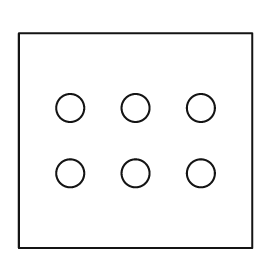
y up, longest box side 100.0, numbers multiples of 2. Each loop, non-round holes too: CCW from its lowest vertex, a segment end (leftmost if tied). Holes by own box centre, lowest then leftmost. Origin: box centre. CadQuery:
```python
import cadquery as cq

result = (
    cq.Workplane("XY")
    .moveTo(-50.0, -46.0)
    .lineTo(50.0, -46.0)
    .lineTo(50.0, 46.0)
    .lineTo(-50.0, 46.0)
    .close()
    .moveTo(-28.0, -14.0)
    .circle(6.0)
    .moveTo(0.0, -14.0)
    .circle(6.0)
    .moveTo(28.0, -14.0)
    .circle(6.0)
    .moveTo(-28.0, 14.0)
    .circle(6.0)
    .moveTo(0.0, 14.0)
    .circle(6.0)
    .moveTo(28.0, 14.0)
    .circle(6.0)
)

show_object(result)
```